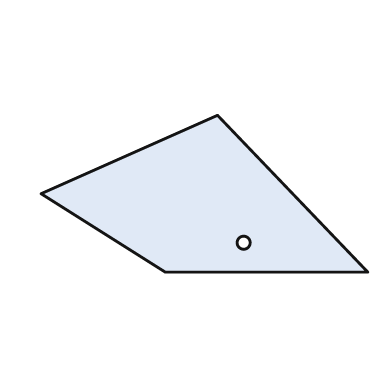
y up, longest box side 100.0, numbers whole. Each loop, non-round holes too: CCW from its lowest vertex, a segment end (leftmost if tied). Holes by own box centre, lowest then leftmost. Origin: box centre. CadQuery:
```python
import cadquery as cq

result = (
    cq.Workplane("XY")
    .moveTo(-12.0, -24.0)
    .lineTo(50.0, -24.0)
    .lineTo(4.0, 24.0)
    .lineTo(-50.0, 0.0)
    .close()
    .moveTo(12.0, -15.0)
    .circle(2.0)
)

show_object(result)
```